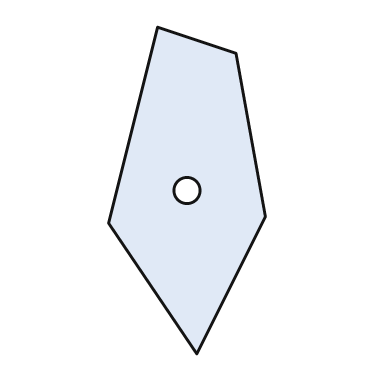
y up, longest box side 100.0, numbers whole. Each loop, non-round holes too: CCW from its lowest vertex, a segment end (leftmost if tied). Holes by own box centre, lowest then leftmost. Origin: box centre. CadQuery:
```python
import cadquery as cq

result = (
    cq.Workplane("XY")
    .moveTo(3.0, -50.0)
    .lineTo(24.0, -8.0)
    .lineTo(15.0, 42.0)
    .lineTo(-9.0, 50.0)
    .lineTo(-24.0, -10.0)
    .close()
    .moveTo(0.0, 0.0)
    .circle(4.0)
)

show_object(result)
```